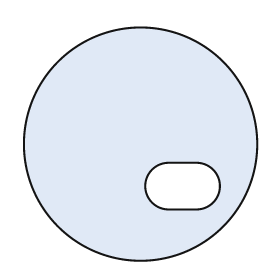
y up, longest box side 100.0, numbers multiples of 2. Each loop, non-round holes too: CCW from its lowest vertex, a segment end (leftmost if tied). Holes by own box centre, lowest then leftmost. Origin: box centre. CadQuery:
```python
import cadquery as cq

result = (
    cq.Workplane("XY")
    .moveTo(0.0, 0.0)
    .circle(50.0)
    .moveTo(12.0, -28.0)
    .lineTo(24.0, -28.0)
    .threePointArc((34.0, -18.0), (24.0, -8.0))
    .lineTo(12.0, -8.0)
    .threePointArc((2.0, -18.0), (12.0, -28.0))
    .close()
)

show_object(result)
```